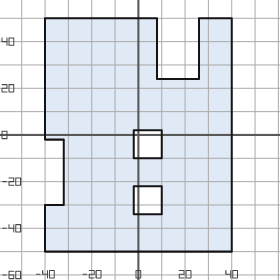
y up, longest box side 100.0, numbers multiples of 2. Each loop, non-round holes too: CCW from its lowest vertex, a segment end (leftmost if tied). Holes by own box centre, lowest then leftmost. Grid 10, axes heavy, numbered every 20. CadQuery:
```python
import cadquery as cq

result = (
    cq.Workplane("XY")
    .moveTo(-40.0, -50.0)
    .lineTo(40.0, -50.0)
    .lineTo(40.0, 50.0)
    .lineTo(26.0, 50.0)
    .lineTo(26.0, 24.0)
    .lineTo(8.0, 24.0)
    .lineTo(8.0, 50.0)
    .lineTo(-40.0, 50.0)
    .lineTo(-40.0, -2.0)
    .lineTo(-32.0, -2.0)
    .lineTo(-32.0, -30.0)
    .lineTo(-40.0, -30.0)
    .close()
    .moveTo(-2.0, -34.0)
    .lineTo(10.0, -34.0)
    .lineTo(10.0, -22.0)
    .lineTo(-2.0, -22.0)
    .close()
    .moveTo(-2.0, -10.0)
    .lineTo(10.0, -10.0)
    .lineTo(10.0, 2.0)
    .lineTo(-2.0, 2.0)
    .close()
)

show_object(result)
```